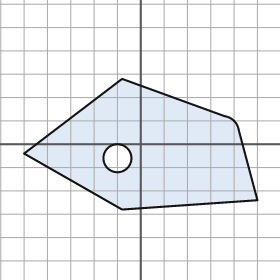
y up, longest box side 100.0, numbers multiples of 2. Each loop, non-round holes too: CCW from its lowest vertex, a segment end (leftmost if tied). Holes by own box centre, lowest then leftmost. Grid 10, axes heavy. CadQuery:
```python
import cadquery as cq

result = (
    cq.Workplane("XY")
    .moveTo(-8.0, -28.0)
    .lineTo(50.0, -24.0)
    .lineTo(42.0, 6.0)
    .threePointArc((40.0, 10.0), (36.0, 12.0))
    .lineTo(-8.0, 28.0)
    .lineTo(-50.0, -4.0)
    .close()
    .moveTo(-10.0, -6.0)
    .circle(6.0)
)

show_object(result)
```